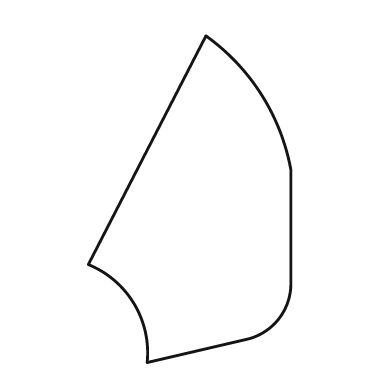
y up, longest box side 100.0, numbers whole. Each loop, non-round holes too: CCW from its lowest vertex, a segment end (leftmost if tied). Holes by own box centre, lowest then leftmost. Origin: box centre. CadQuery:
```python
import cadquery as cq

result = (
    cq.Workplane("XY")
    .moveTo(-13.0, -50.0)
    .lineTo(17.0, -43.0)
    .threePointArc((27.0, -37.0), (31.0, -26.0))
    .lineTo(31.0, 9.0)
    .threePointArc((22.0, 32.0), (5.0, 50.0))
    .lineTo(-31.0, -20.0)
    .threePointArc((-17.0, -32.0), (-13.0, -50.0))
    .close()
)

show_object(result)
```